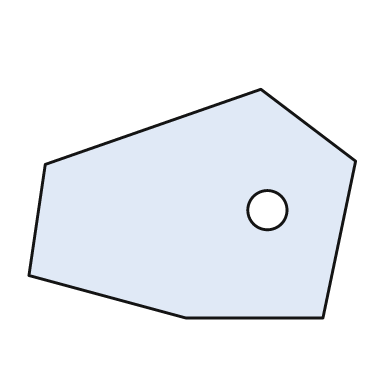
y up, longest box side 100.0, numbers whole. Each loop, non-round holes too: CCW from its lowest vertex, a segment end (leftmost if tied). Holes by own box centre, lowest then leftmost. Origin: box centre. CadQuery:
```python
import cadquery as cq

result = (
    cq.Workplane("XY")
    .moveTo(-2.0, -35.0)
    .lineTo(40.0, -35.0)
    .lineTo(50.0, 13.0)
    .lineTo(21.0, 35.0)
    .lineTo(-45.0, 12.0)
    .lineTo(-50.0, -22.0)
    .close()
    .moveTo(23.0, -2.0)
    .circle(6.0)
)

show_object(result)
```